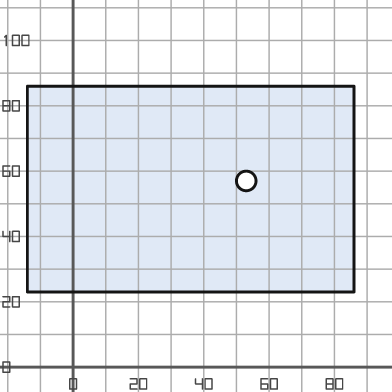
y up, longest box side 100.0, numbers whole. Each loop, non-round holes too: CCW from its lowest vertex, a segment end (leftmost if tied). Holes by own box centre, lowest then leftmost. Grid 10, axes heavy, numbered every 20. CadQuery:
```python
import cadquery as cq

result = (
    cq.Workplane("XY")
    .moveTo(-14.0, 23.0)
    .lineTo(86.0, 23.0)
    .lineTo(86.0, 86.0)
    .lineTo(-14.0, 86.0)
    .close()
    .moveTo(53.0, 57.0)
    .circle(3.0)
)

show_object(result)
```